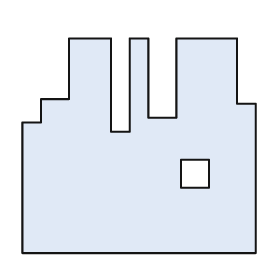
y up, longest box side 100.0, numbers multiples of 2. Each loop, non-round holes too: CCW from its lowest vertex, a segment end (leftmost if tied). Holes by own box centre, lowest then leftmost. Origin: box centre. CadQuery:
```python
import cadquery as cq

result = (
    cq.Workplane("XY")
    .moveTo(-50.0, -46.0)
    .lineTo(50.0, -46.0)
    .lineTo(50.0, 18.0)
    .lineTo(42.0, 18.0)
    .lineTo(42.0, 46.0)
    .lineTo(16.0, 46.0)
    .lineTo(16.0, 12.0)
    .lineTo(4.0, 12.0)
    .lineTo(4.0, 46.0)
    .lineTo(-4.0, 46.0)
    .lineTo(-4.0, 6.0)
    .lineTo(-12.0, 6.0)
    .lineTo(-12.0, 46.0)
    .lineTo(-30.0, 46.0)
    .lineTo(-30.0, 20.0)
    .lineTo(-42.0, 20.0)
    .lineTo(-42.0, 10.0)
    .lineTo(-50.0, 10.0)
    .close()
    .moveTo(18.0, -18.0)
    .lineTo(30.0, -18.0)
    .lineTo(30.0, -6.0)
    .lineTo(18.0, -6.0)
    .close()
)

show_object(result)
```